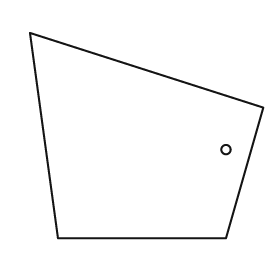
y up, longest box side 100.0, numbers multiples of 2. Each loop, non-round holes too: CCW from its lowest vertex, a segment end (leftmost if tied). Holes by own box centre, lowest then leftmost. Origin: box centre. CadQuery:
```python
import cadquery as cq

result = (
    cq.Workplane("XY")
    .moveTo(-38.0, -44.0)
    .lineTo(34.0, -44.0)
    .lineTo(50.0, 12.0)
    .lineTo(-50.0, 44.0)
    .close()
    .moveTo(34.0, -6.0)
    .circle(2.0)
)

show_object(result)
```